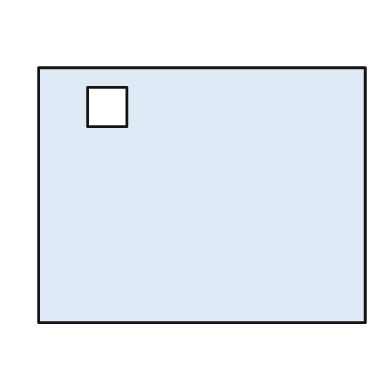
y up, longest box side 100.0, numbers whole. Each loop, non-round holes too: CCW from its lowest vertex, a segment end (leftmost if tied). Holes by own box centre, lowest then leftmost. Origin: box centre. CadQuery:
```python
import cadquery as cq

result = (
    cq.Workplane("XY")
    .moveTo(-50.0, -39.0)
    .lineTo(50.0, -39.0)
    .lineTo(50.0, 39.0)
    .lineTo(-50.0, 39.0)
    .close()
    .moveTo(-35.0, 21.0)
    .lineTo(-23.0, 21.0)
    .lineTo(-23.0, 33.0)
    .lineTo(-35.0, 33.0)
    .close()
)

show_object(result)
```